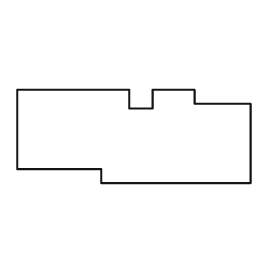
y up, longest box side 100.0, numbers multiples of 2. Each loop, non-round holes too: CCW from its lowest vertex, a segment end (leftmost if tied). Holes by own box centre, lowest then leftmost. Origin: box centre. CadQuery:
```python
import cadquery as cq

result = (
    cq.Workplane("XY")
    .moveTo(-14.0, -20.0)
    .lineTo(50.0, -20.0)
    .lineTo(50.0, 14.0)
    .lineTo(26.0, 14.0)
    .lineTo(26.0, 20.0)
    .lineTo(8.0, 20.0)
    .lineTo(8.0, 12.0)
    .lineTo(-2.0, 12.0)
    .lineTo(-2.0, 20.0)
    .lineTo(-50.0, 20.0)
    .lineTo(-50.0, -14.0)
    .lineTo(-14.0, -14.0)
    .close()
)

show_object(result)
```